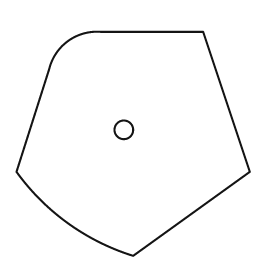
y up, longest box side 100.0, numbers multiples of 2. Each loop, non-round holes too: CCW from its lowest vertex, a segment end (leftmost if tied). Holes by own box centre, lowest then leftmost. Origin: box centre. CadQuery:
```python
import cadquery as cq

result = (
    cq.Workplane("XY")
    .moveTo(0.0, -48.0)
    .lineTo(50.0, -12.0)
    .lineTo(30.0, 48.0)
    .lineTo(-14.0, 48.0)
    .threePointArc((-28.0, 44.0), (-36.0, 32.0))
    .lineTo(-50.0, -12.0)
    .threePointArc((-28.0, -34.0), (0.0, -48.0))
    .close()
    .moveTo(-4.0, 6.0)
    .circle(4.0)
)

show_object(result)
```